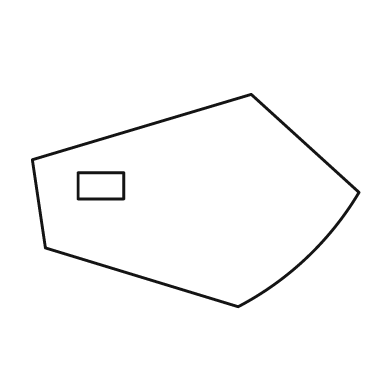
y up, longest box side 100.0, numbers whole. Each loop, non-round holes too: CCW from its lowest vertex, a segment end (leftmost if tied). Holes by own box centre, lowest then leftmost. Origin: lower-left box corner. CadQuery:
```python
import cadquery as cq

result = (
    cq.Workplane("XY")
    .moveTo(63.0, 0.0)
    .threePointArc((84.0, 15.0), (100.0, 35.0))
    .lineTo(67.0, 65.0)
    .lineTo(0.0, 45.0)
    .lineTo(4.0, 18.0)
    .close()
    .moveTo(14.0, 33.0)
    .lineTo(28.0, 33.0)
    .lineTo(28.0, 41.0)
    .lineTo(14.0, 41.0)
    .close()
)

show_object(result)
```